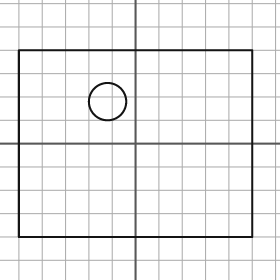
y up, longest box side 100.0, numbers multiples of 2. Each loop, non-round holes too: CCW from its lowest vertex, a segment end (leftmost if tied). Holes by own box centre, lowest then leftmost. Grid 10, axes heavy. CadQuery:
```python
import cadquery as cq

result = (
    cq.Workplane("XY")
    .moveTo(-50.0, -40.0)
    .lineTo(50.0, -40.0)
    .lineTo(50.0, 40.0)
    .lineTo(-50.0, 40.0)
    .close()
    .moveTo(-12.0, 18.0)
    .circle(8.0)
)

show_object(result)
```